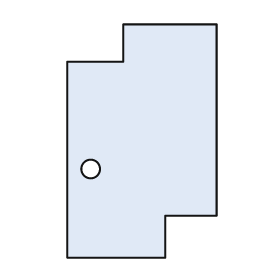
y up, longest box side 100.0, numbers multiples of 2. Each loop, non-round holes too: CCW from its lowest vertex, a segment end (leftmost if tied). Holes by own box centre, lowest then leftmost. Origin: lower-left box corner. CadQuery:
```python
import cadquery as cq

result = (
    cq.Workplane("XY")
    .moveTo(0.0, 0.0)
    .lineTo(42.0, 0.0)
    .lineTo(42.0, 18.0)
    .lineTo(64.0, 18.0)
    .lineTo(64.0, 100.0)
    .lineTo(24.0, 100.0)
    .lineTo(24.0, 84.0)
    .lineTo(0.0, 84.0)
    .close()
    .moveTo(10.0, 38.0)
    .circle(4.0)
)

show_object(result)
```